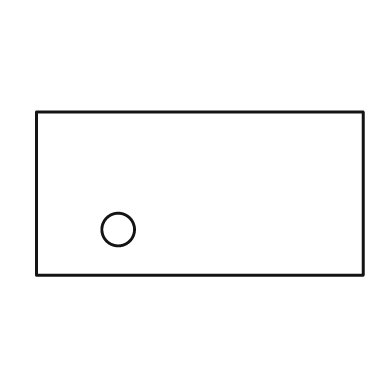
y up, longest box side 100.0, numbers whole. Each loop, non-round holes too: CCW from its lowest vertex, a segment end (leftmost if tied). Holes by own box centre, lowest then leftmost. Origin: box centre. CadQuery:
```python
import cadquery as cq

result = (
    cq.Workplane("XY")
    .moveTo(-50.0, -25.0)
    .lineTo(50.0, -25.0)
    .lineTo(50.0, 25.0)
    .lineTo(-50.0, 25.0)
    .close()
    .moveTo(-25.0, -11.0)
    .circle(5.0)
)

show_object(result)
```